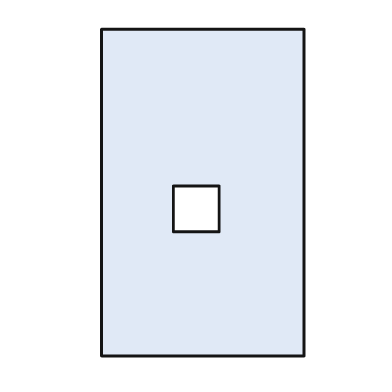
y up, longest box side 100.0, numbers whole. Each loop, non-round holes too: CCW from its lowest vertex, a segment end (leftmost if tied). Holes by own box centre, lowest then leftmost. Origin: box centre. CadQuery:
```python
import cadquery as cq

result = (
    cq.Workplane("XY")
    .moveTo(-31.0, -50.0)
    .lineTo(31.0, -50.0)
    .lineTo(31.0, 50.0)
    .lineTo(-31.0, 50.0)
    .close()
    .moveTo(-9.0, -12.0)
    .lineTo(5.0, -12.0)
    .lineTo(5.0, 2.0)
    .lineTo(-9.0, 2.0)
    .close()
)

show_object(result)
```